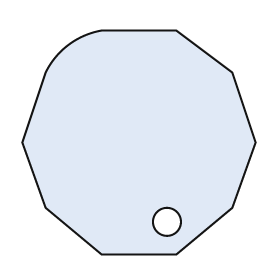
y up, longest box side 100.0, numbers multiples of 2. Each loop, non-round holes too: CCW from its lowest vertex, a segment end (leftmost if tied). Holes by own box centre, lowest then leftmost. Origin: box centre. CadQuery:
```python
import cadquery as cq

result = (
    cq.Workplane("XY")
    .moveTo(-16.0, -48.0)
    .lineTo(16.0, -48.0)
    .lineTo(40.0, -28.0)
    .lineTo(50.0, 0.0)
    .lineTo(40.0, 30.0)
    .lineTo(16.0, 48.0)
    .lineTo(-16.0, 48.0)
    .threePointArc((-30.0, 42.0), (-40.0, 30.0))
    .lineTo(-50.0, 0.0)
    .lineTo(-40.0, -28.0)
    .close()
    .moveTo(12.0, -34.0)
    .circle(6.0)
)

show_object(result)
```